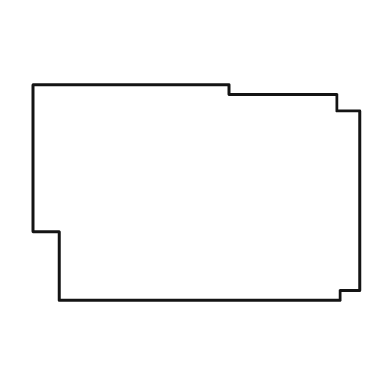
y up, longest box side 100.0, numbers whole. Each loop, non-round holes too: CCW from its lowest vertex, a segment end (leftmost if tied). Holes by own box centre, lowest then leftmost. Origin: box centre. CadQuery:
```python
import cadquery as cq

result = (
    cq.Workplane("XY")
    .moveTo(-42.0, -33.0)
    .lineTo(44.0, -33.0)
    .lineTo(44.0, -30.0)
    .lineTo(50.0, -30.0)
    .lineTo(50.0, 25.0)
    .lineTo(43.0, 25.0)
    .lineTo(43.0, 30.0)
    .lineTo(10.0, 30.0)
    .lineTo(10.0, 33.0)
    .lineTo(-50.0, 33.0)
    .lineTo(-50.0, -12.0)
    .lineTo(-42.0, -12.0)
    .close()
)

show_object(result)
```